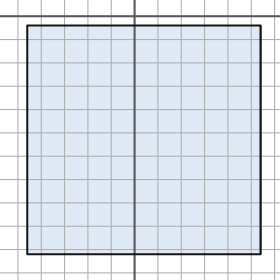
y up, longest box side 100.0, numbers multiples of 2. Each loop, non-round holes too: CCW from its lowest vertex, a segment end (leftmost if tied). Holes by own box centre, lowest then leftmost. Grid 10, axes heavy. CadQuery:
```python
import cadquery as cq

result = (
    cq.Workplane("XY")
    .moveTo(-46.0, -102.0)
    .lineTo(54.0, -102.0)
    .lineTo(54.0, -4.0)
    .lineTo(-46.0, -4.0)
    .close()
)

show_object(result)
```